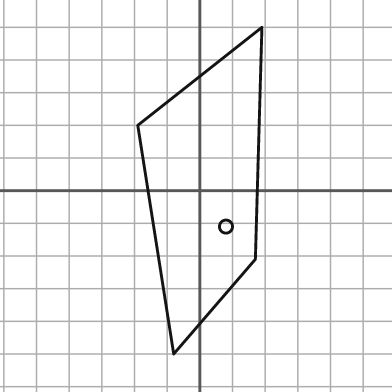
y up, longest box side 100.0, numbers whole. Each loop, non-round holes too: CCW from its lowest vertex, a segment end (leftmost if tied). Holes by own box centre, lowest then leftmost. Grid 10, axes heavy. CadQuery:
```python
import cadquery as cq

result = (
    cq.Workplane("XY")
    .moveTo(-8.0, -50.0)
    .lineTo(17.0, -21.0)
    .lineTo(19.0, 50.0)
    .lineTo(-19.0, 20.0)
    .close()
    .moveTo(8.0, -11.0)
    .circle(2.0)
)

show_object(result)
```